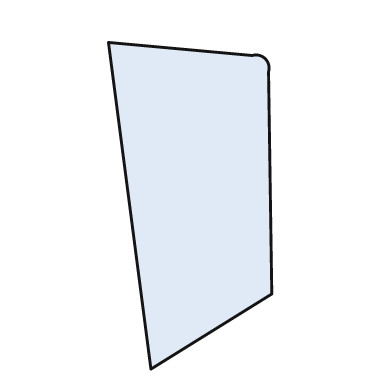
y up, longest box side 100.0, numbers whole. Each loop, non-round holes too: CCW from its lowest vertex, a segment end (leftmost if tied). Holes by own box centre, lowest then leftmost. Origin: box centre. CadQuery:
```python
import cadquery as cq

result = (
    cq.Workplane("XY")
    .moveTo(-12.0, -50.0)
    .lineTo(25.0, -27.0)
    .lineTo(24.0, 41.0)
    .threePointArc((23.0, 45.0), (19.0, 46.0))
    .lineTo(-25.0, 50.0)
    .close()
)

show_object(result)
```